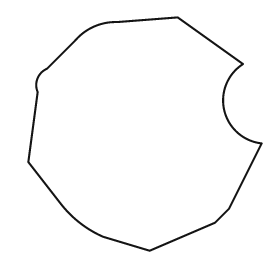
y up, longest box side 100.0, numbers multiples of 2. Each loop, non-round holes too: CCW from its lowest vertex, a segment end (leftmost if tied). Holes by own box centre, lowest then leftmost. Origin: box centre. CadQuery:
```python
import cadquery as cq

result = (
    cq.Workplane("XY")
    .moveTo(2.0, -50.0)
    .lineTo(30.0, -38.0)
    .lineTo(36.0, -32.0)
    .lineTo(50.0, -4.0)
    .threePointArc((34.0, 10.0), (42.0, 30.0))
    .lineTo(14.0, 50.0)
    .lineTo(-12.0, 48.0)
    .threePointArc((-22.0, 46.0), (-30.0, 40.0))
    .lineTo(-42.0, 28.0)
    .threePointArc((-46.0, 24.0), (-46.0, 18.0))
    .lineTo(-50.0, -12.0)
    .lineTo(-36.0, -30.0)
    .threePointArc((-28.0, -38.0), (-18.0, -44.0))
    .close()
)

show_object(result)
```